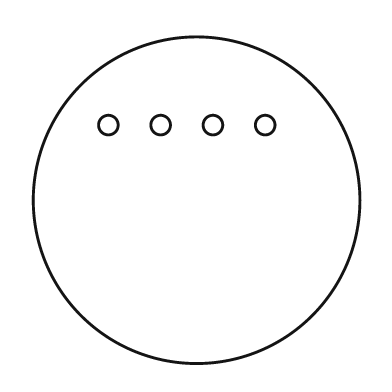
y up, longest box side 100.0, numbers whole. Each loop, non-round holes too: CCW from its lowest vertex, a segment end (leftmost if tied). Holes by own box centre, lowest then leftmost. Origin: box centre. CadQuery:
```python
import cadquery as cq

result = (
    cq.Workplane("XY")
    .moveTo(0.0, 0.0)
    .circle(50.0)
    .moveTo(-27.0, 23.0)
    .circle(3.0)
    .moveTo(-11.0, 23.0)
    .circle(3.0)
    .moveTo(5.0, 23.0)
    .circle(3.0)
    .moveTo(21.0, 23.0)
    .circle(3.0)
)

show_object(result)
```